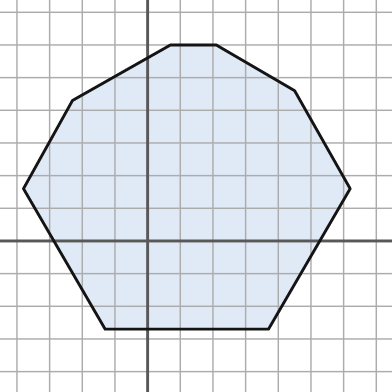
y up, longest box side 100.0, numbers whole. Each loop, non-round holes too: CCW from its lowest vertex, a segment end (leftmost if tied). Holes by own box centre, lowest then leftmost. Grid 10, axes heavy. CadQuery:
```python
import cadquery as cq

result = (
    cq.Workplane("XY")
    .moveTo(-13.0, -27.0)
    .lineTo(37.0, -27.0)
    .lineTo(62.0, 16.0)
    .lineTo(45.0, 46.0)
    .lineTo(21.0, 60.0)
    .lineTo(7.0, 60.0)
    .lineTo(-23.0, 43.0)
    .lineTo(-38.0, 16.0)
    .close()
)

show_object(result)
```